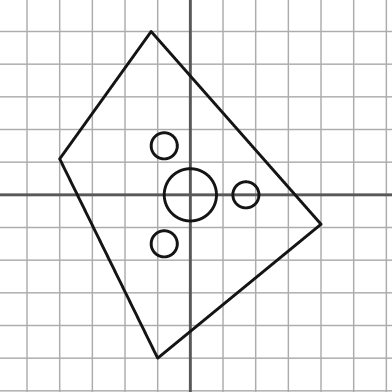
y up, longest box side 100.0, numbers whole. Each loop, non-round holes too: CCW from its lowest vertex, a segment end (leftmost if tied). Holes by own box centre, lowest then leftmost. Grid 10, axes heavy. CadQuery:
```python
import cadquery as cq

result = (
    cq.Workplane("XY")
    .moveTo(-10.0, -50.0)
    .lineTo(40.0, -9.0)
    .lineTo(-12.0, 50.0)
    .lineTo(-40.0, 11.0)
    .close()
    .moveTo(-8.0, -15.0)
    .circle(4.0)
    .moveTo(0.0, 0.0)
    .circle(8.0)
    .moveTo(17.0, 0.0)
    .circle(4.0)
    .moveTo(-8.0, 15.0)
    .circle(4.0)
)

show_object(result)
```